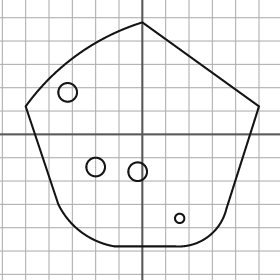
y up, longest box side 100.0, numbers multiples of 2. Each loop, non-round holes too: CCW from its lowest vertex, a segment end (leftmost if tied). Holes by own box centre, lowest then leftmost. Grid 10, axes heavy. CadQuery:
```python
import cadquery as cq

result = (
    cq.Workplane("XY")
    .moveTo(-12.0, -48.0)
    .lineTo(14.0, -48.0)
    .threePointArc((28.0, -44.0), (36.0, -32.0))
    .lineTo(50.0, 12.0)
    .lineTo(0.0, 48.0)
    .threePointArc((-28.0, 34.0), (-50.0, 12.0))
    .lineTo(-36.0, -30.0)
    .threePointArc((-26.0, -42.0), (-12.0, -48.0))
    .close()
    .moveTo(16.0, -36.0)
    .circle(2.0)
    .moveTo(-2.0, -16.0)
    .circle(4.0)
    .moveTo(-20.0, -14.0)
    .circle(4.0)
    .moveTo(-32.0, 18.0)
    .circle(4.0)
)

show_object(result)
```